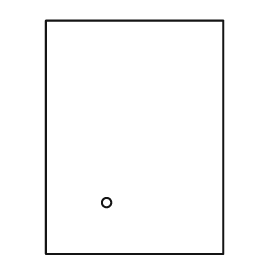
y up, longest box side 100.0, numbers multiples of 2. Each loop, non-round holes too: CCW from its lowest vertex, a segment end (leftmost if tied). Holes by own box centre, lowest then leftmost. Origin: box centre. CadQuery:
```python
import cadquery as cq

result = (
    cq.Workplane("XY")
    .moveTo(-38.0, -50.0)
    .lineTo(38.0, -50.0)
    .lineTo(38.0, 50.0)
    .lineTo(-38.0, 50.0)
    .close()
    .moveTo(-12.0, -28.0)
    .circle(2.0)
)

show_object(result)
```